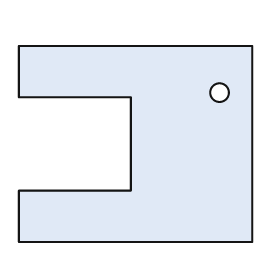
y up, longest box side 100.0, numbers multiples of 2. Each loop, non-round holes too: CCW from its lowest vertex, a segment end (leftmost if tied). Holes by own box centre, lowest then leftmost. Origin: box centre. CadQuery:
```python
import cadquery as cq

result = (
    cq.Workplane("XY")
    .moveTo(-50.0, -42.0)
    .lineTo(50.0, -42.0)
    .lineTo(50.0, 42.0)
    .lineTo(-50.0, 42.0)
    .lineTo(-50.0, 20.0)
    .lineTo(-2.0, 20.0)
    .lineTo(-2.0, -20.0)
    .lineTo(-50.0, -20.0)
    .close()
    .moveTo(36.0, 22.0)
    .circle(4.0)
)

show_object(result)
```